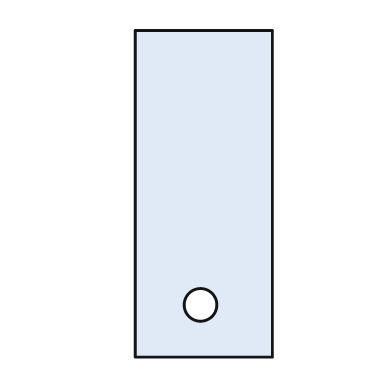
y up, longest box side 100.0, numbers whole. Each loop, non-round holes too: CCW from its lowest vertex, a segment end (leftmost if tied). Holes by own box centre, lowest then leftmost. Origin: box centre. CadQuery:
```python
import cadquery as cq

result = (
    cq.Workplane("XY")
    .moveTo(-21.0, -50.0)
    .lineTo(21.0, -50.0)
    .lineTo(21.0, 50.0)
    .lineTo(-21.0, 50.0)
    .close()
    .moveTo(-1.0, -34.0)
    .circle(5.0)
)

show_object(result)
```